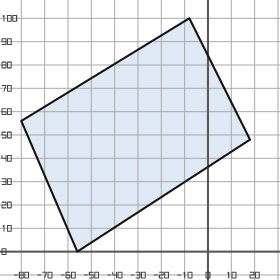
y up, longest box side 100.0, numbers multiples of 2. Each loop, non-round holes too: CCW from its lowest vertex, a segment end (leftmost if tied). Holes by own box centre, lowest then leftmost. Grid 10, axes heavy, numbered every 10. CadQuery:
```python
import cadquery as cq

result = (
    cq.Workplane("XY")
    .moveTo(-56.0, 0.0)
    .lineTo(18.0, 48.0)
    .lineTo(-8.0, 100.0)
    .lineTo(-80.0, 56.0)
    .close()
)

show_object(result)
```